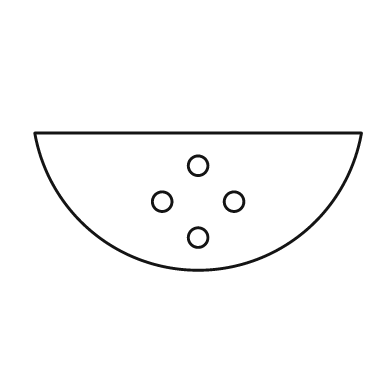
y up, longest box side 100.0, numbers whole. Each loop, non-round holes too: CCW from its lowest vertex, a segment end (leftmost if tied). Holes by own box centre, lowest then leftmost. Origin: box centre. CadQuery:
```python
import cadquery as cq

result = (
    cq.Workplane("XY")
    .moveTo(-50.0, 21.0)
    .threePointArc((0.0, -21.0), (50.0, 21.0))
    .close()
    .moveTo(0.0, -11.0)
    .circle(3.0)
    .moveTo(-11.0, 0.0)
    .circle(3.0)
    .moveTo(11.0, 0.0)
    .circle(3.0)
    .moveTo(0.0, 11.0)
    .circle(3.0)
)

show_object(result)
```